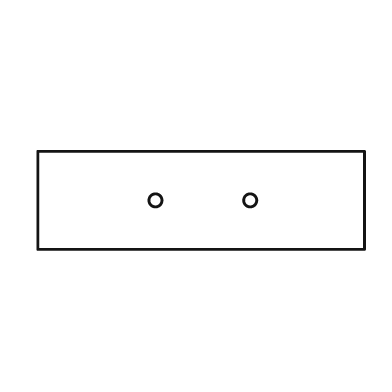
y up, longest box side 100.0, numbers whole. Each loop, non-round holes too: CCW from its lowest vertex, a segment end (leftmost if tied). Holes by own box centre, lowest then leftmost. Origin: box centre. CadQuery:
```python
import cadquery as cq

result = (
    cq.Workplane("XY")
    .moveTo(-50.0, -15.0)
    .lineTo(50.0, -15.0)
    .lineTo(50.0, 15.0)
    .lineTo(-50.0, 15.0)
    .close()
    .moveTo(-14.0, 0.0)
    .circle(2.0)
    .moveTo(15.0, 0.0)
    .circle(2.0)
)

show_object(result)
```